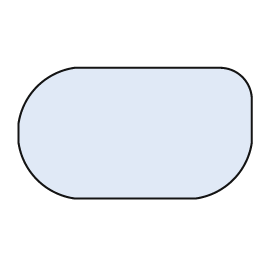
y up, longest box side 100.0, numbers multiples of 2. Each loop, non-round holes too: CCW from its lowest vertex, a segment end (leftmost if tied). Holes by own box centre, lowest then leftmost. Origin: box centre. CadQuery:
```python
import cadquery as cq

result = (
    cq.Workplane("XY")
    .moveTo(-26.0, -28.0)
    .lineTo(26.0, -28.0)
    .threePointArc((42.0, -20.0), (50.0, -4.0))
    .lineTo(50.0, 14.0)
    .threePointArc((46.0, 24.0), (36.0, 28.0))
    .lineTo(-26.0, 28.0)
    .threePointArc((-42.0, 20.0), (-50.0, 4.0))
    .lineTo(-50.0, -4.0)
    .threePointArc((-42.0, -20.0), (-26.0, -28.0))
    .close()
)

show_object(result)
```